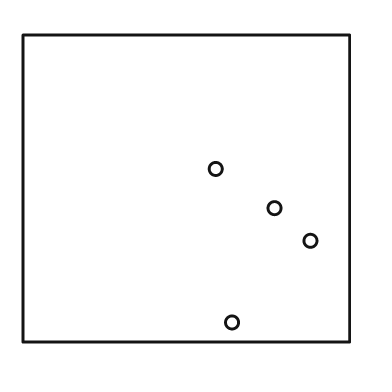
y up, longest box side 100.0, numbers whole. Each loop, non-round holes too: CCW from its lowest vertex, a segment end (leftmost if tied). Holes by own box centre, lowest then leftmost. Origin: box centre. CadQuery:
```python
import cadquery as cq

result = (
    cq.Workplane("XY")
    .moveTo(-50.0, -47.0)
    .lineTo(50.0, -47.0)
    .lineTo(50.0, 47.0)
    .lineTo(-50.0, 47.0)
    .close()
    .moveTo(14.0, -41.0)
    .circle(2.0)
    .moveTo(38.0, -16.0)
    .circle(2.0)
    .moveTo(27.0, -6.0)
    .circle(2.0)
    .moveTo(9.0, 6.0)
    .circle(2.0)
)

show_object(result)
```